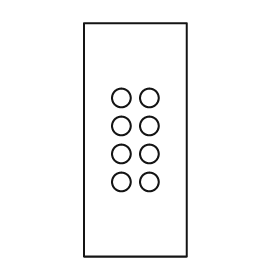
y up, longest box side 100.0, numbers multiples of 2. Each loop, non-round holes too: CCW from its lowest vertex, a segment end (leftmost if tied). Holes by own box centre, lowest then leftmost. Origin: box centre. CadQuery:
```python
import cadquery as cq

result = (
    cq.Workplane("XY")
    .moveTo(-22.0, -50.0)
    .lineTo(22.0, -50.0)
    .lineTo(22.0, 50.0)
    .lineTo(-22.0, 50.0)
    .close()
    .moveTo(-6.0, -18.0)
    .circle(4.0)
    .moveTo(6.0, -18.0)
    .circle(4.0)
    .moveTo(-6.0, -6.0)
    .circle(4.0)
    .moveTo(6.0, -6.0)
    .circle(4.0)
    .moveTo(-6.0, 6.0)
    .circle(4.0)
    .moveTo(6.0, 6.0)
    .circle(4.0)
    .moveTo(-6.0, 18.0)
    .circle(4.0)
    .moveTo(6.0, 18.0)
    .circle(4.0)
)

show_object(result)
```